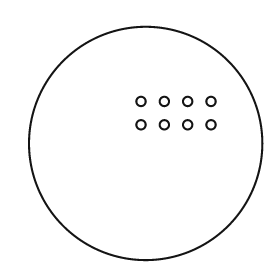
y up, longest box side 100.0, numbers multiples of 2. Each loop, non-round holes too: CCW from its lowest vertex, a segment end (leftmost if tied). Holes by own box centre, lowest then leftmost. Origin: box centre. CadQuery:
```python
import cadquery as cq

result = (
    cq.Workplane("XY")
    .moveTo(0.0, 0.0)
    .circle(50.0)
    .moveTo(-2.0, 8.0)
    .circle(2.0)
    .moveTo(8.0, 8.0)
    .circle(2.0)
    .moveTo(18.0, 8.0)
    .circle(2.0)
    .moveTo(28.0, 8.0)
    .circle(2.0)
    .moveTo(-2.0, 18.0)
    .circle(2.0)
    .moveTo(8.0, 18.0)
    .circle(2.0)
    .moveTo(18.0, 18.0)
    .circle(2.0)
    .moveTo(28.0, 18.0)
    .circle(2.0)
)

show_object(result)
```